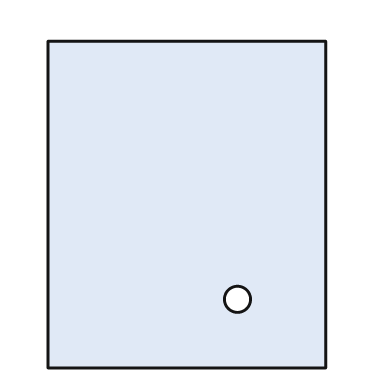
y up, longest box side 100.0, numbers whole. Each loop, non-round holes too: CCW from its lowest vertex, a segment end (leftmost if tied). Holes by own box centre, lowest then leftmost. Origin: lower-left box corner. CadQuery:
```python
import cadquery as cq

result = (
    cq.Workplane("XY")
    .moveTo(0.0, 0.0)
    .lineTo(85.0, 0.0)
    .lineTo(85.0, 100.0)
    .lineTo(0.0, 100.0)
    .close()
    .moveTo(58.0, 21.0)
    .circle(4.0)
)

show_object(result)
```